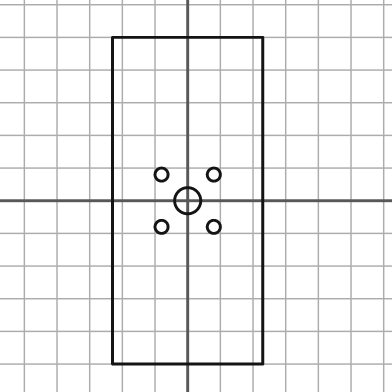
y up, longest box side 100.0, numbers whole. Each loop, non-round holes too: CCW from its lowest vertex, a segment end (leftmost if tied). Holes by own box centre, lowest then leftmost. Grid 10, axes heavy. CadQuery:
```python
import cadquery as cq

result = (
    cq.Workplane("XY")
    .moveTo(-23.0, -50.0)
    .lineTo(23.0, -50.0)
    .lineTo(23.0, 50.0)
    .lineTo(-23.0, 50.0)
    .close()
    .moveTo(-8.0, -8.0)
    .circle(2.0)
    .moveTo(8.0, -8.0)
    .circle(2.0)
    .moveTo(0.0, 0.0)
    .circle(4.0)
    .moveTo(-8.0, 8.0)
    .circle(2.0)
    .moveTo(8.0, 8.0)
    .circle(2.0)
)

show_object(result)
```